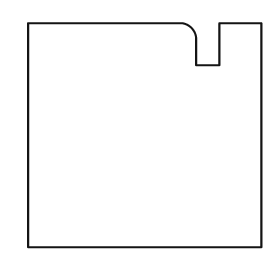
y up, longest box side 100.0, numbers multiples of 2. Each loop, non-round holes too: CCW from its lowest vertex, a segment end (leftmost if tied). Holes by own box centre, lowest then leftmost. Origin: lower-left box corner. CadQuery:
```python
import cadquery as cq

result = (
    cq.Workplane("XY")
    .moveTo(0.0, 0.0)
    .lineTo(100.0, 0.0)
    .lineTo(100.0, 96.0)
    .lineTo(82.0, 96.0)
    .lineTo(82.0, 78.0)
    .lineTo(72.0, 78.0)
    .lineTo(72.0, 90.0)
    .threePointArc((70.0, 94.0), (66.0, 96.0))
    .lineTo(0.0, 96.0)
    .close()
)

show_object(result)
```